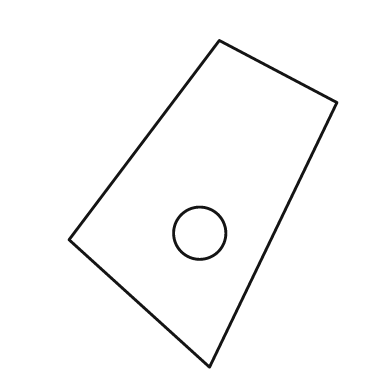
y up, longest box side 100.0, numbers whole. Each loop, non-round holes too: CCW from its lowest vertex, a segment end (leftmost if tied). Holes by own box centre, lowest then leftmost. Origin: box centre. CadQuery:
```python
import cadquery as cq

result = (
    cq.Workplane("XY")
    .moveTo(2.0, -50.0)
    .lineTo(41.0, 31.0)
    .lineTo(5.0, 50.0)
    .lineTo(-41.0, -11.0)
    .close()
    .moveTo(-1.0, -9.0)
    .circle(8.0)
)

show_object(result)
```